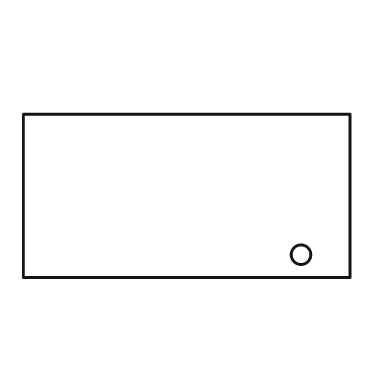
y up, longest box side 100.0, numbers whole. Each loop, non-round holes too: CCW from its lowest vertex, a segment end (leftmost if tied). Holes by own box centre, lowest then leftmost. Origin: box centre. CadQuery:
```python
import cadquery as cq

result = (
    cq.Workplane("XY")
    .moveTo(-50.0, -25.0)
    .lineTo(50.0, -25.0)
    .lineTo(50.0, 25.0)
    .lineTo(-50.0, 25.0)
    .close()
    .moveTo(35.0, -18.0)
    .circle(3.0)
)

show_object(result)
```